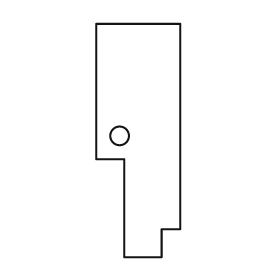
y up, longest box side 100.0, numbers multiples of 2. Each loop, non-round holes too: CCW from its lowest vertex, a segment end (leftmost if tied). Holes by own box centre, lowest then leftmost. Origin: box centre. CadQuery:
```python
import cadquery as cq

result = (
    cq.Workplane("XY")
    .moveTo(-6.0, -50.0)
    .lineTo(10.0, -50.0)
    .lineTo(10.0, -38.0)
    .lineTo(18.0, -38.0)
    .lineTo(18.0, 50.0)
    .lineTo(-18.0, 50.0)
    .lineTo(-18.0, -8.0)
    .lineTo(-6.0, -8.0)
    .close()
    .moveTo(-8.0, 2.0)
    .circle(4.0)
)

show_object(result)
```